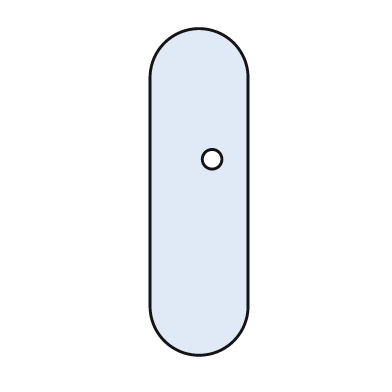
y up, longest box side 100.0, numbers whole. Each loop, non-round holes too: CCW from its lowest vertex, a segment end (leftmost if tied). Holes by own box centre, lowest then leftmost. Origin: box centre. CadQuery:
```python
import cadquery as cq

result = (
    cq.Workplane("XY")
    .moveTo(-15.0, -35.0)
    .threePointArc((0.0, -50.0), (15.0, -35.0))
    .lineTo(15.0, 35.0)
    .threePointArc((0.0, 50.0), (-15.0, 35.0))
    .close()
    .moveTo(4.0, 10.0)
    .circle(3.0)
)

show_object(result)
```